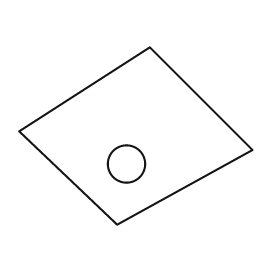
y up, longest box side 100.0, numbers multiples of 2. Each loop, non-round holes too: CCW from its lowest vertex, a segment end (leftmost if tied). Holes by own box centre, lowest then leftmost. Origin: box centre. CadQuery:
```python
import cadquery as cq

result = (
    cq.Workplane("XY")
    .moveTo(-8.0, -38.0)
    .lineTo(50.0, -6.0)
    .lineTo(6.0, 38.0)
    .lineTo(-50.0, 2.0)
    .close()
    .moveTo(-4.0, -12.0)
    .circle(8.0)
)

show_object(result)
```